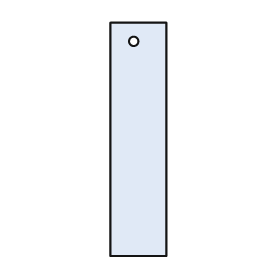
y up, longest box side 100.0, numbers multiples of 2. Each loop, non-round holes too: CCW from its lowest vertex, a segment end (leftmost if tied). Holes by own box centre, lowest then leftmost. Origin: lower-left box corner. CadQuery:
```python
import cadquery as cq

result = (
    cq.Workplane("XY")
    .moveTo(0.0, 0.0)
    .lineTo(24.0, 0.0)
    .lineTo(24.0, 100.0)
    .lineTo(0.0, 100.0)
    .close()
    .moveTo(10.0, 92.0)
    .circle(2.0)
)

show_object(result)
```